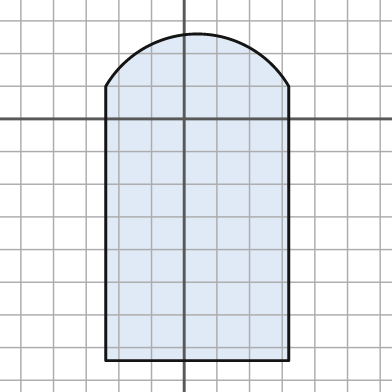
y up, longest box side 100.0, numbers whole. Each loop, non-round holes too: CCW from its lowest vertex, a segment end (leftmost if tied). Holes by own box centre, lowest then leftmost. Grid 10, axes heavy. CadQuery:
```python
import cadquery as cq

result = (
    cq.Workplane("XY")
    .moveTo(-24.0, -74.0)
    .lineTo(32.0, -74.0)
    .lineTo(32.0, 10.0)
    .threePointArc((4.0, 26.0), (-24.0, 10.0))
    .close()
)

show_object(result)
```